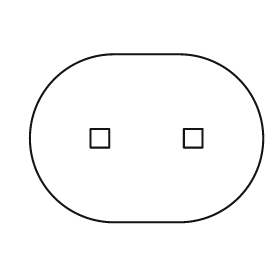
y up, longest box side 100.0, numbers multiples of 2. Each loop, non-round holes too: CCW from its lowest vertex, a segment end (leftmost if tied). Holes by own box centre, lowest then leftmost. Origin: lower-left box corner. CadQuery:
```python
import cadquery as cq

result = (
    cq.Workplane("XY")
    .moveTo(36.0, 0.0)
    .lineTo(64.0, 0.0)
    .threePointArc((100.0, 36.0), (64.0, 72.0))
    .lineTo(36.0, 72.0)
    .threePointArc((0.0, 36.0), (36.0, 0.0))
    .close()
    .moveTo(26.0, 32.0)
    .lineTo(34.0, 32.0)
    .lineTo(34.0, 40.0)
    .lineTo(26.0, 40.0)
    .close()
    .moveTo(66.0, 32.0)
    .lineTo(74.0, 32.0)
    .lineTo(74.0, 40.0)
    .lineTo(66.0, 40.0)
    .close()
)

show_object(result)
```